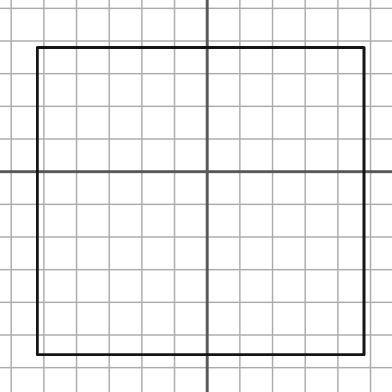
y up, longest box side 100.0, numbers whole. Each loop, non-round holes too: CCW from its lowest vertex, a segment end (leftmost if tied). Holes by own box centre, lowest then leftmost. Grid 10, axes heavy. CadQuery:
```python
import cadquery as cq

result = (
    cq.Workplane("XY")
    .moveTo(-52.0, -56.0)
    .lineTo(48.0, -56.0)
    .lineTo(48.0, 38.0)
    .lineTo(-52.0, 38.0)
    .close()
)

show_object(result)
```